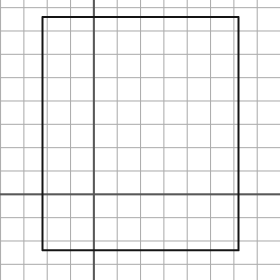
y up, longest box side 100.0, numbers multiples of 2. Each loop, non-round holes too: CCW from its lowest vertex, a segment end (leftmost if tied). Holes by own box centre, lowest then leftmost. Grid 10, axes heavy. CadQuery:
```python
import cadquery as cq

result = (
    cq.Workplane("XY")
    .moveTo(-22.0, -24.0)
    .lineTo(62.0, -24.0)
    .lineTo(62.0, 76.0)
    .lineTo(-22.0, 76.0)
    .close()
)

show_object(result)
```